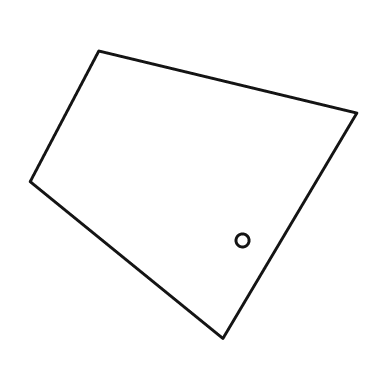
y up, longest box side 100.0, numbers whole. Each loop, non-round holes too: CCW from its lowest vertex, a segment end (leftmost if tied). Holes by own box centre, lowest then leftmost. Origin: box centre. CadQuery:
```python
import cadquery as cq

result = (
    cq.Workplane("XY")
    .moveTo(9.0, -44.0)
    .lineTo(50.0, 25.0)
    .lineTo(-29.0, 44.0)
    .lineTo(-50.0, 4.0)
    .close()
    .moveTo(15.0, -14.0)
    .circle(2.0)
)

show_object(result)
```